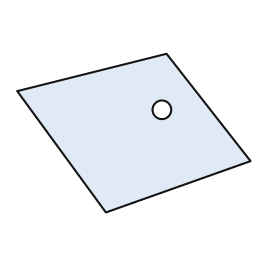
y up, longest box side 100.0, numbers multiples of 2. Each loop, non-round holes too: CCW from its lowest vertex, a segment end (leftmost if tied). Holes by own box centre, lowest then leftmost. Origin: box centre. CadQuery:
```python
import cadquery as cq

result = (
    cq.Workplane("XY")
    .moveTo(-12.0, -34.0)
    .lineTo(50.0, -12.0)
    .lineTo(14.0, 34.0)
    .lineTo(-50.0, 18.0)
    .close()
    .moveTo(12.0, 10.0)
    .circle(4.0)
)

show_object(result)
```